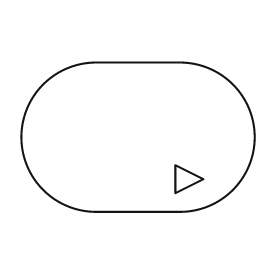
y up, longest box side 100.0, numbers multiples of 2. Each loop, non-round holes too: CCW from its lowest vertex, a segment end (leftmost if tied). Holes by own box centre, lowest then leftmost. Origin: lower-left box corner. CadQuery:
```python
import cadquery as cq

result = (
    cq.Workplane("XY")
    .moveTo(32.0, 0.0)
    .lineTo(68.0, 0.0)
    .threePointArc((100.0, 32.0), (68.0, 64.0))
    .lineTo(32.0, 64.0)
    .threePointArc((0.0, 32.0), (32.0, 0.0))
    .close()
    .moveTo(66.0, 8.0)
    .lineTo(78.0, 14.0)
    .lineTo(66.0, 20.0)
    .close()
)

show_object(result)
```